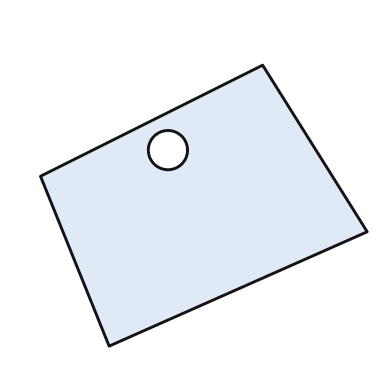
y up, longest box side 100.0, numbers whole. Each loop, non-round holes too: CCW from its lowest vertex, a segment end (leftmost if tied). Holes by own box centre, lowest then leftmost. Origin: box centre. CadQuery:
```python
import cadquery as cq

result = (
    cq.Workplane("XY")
    .moveTo(-29.0, -43.0)
    .lineTo(50.0, -8.0)
    .lineTo(18.0, 43.0)
    .lineTo(-50.0, 9.0)
    .close()
    .moveTo(-11.0, 17.0)
    .circle(6.0)
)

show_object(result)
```